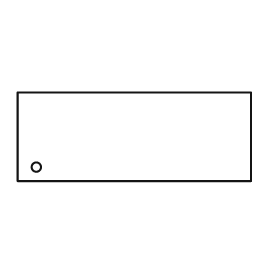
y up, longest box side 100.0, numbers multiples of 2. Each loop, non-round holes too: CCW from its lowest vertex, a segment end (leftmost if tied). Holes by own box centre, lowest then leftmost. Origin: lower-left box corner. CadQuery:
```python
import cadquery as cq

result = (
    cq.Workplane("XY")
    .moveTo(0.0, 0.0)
    .lineTo(100.0, 0.0)
    .lineTo(100.0, 38.0)
    .lineTo(0.0, 38.0)
    .close()
    .moveTo(8.0, 6.0)
    .circle(2.0)
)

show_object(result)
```